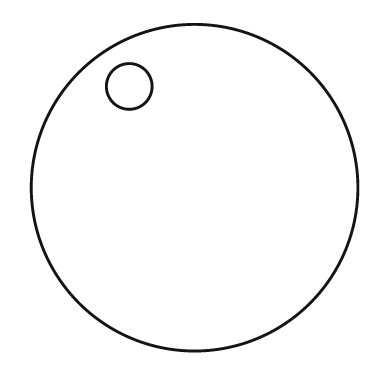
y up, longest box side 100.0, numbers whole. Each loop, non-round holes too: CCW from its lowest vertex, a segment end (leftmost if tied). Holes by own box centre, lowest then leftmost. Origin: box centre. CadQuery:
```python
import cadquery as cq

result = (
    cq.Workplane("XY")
    .moveTo(0.0, 0.0)
    .circle(50.0)
    .moveTo(-20.0, 31.0)
    .circle(7.0)
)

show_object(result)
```